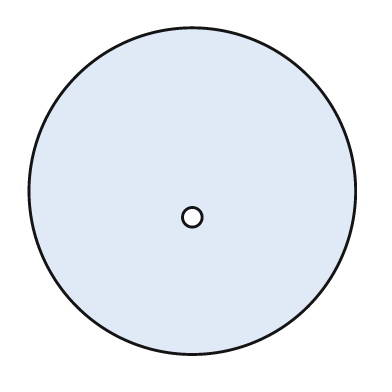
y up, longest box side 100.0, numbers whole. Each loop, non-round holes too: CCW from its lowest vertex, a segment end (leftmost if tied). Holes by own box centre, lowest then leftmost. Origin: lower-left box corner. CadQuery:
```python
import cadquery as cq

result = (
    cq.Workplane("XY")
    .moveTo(50.0, 50.0)
    .circle(50.0)
    .moveTo(50.0, 42.0)
    .circle(3.0)
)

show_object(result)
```